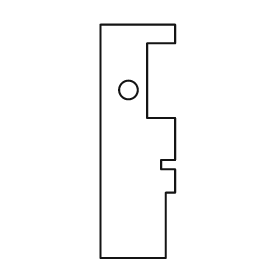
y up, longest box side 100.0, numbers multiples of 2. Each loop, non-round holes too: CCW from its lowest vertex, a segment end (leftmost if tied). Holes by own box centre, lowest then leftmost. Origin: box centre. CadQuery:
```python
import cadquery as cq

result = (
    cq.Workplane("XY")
    .moveTo(-16.0, -50.0)
    .lineTo(12.0, -50.0)
    .lineTo(12.0, -22.0)
    .lineTo(16.0, -22.0)
    .lineTo(16.0, -12.0)
    .lineTo(10.0, -12.0)
    .lineTo(10.0, -8.0)
    .lineTo(16.0, -8.0)
    .lineTo(16.0, 10.0)
    .lineTo(4.0, 10.0)
    .lineTo(4.0, 42.0)
    .lineTo(16.0, 42.0)
    .lineTo(16.0, 50.0)
    .lineTo(-16.0, 50.0)
    .close()
    .moveTo(-4.0, 22.0)
    .circle(4.0)
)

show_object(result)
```